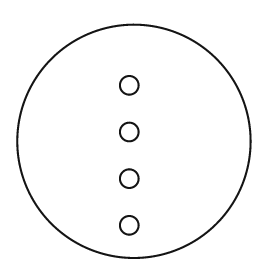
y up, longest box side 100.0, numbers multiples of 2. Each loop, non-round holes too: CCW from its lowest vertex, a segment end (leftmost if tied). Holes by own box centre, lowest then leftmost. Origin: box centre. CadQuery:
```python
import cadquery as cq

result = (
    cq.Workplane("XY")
    .moveTo(0.0, 0.0)
    .circle(50.0)
    .moveTo(-2.0, -36.0)
    .circle(4.0)
    .moveTo(-2.0, -16.0)
    .circle(4.0)
    .moveTo(-2.0, 4.0)
    .circle(4.0)
    .moveTo(-2.0, 24.0)
    .circle(4.0)
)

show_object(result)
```